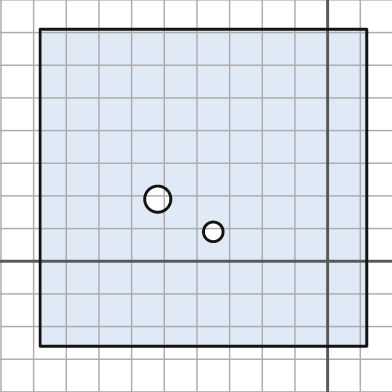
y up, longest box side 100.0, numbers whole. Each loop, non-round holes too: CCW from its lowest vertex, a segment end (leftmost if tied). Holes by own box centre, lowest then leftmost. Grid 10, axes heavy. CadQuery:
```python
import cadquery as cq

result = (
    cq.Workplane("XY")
    .moveTo(-88.0, -26.0)
    .lineTo(12.0, -26.0)
    .lineTo(12.0, 71.0)
    .lineTo(-88.0, 71.0)
    .close()
    .moveTo(-35.0, 9.0)
    .circle(3.0)
    .moveTo(-52.0, 19.0)
    .circle(4.0)
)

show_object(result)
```